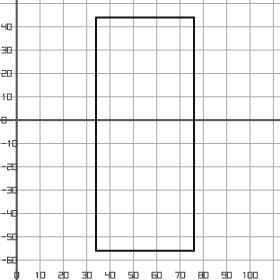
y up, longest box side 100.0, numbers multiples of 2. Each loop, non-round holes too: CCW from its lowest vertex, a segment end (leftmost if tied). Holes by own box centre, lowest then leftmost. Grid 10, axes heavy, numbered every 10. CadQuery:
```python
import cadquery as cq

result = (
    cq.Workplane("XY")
    .moveTo(34.0, -56.0)
    .lineTo(76.0, -56.0)
    .lineTo(76.0, 44.0)
    .lineTo(34.0, 44.0)
    .close()
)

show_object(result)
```